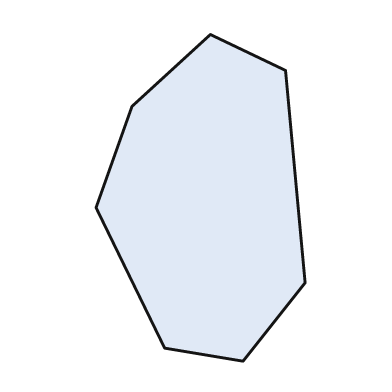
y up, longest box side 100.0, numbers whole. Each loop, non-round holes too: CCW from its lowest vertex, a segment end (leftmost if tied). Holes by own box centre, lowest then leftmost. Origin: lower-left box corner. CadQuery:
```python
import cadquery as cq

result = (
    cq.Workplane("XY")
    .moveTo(45.0, 0.0)
    .lineTo(64.0, 24.0)
    .lineTo(58.0, 89.0)
    .lineTo(35.0, 100.0)
    .lineTo(11.0, 78.0)
    .lineTo(0.0, 47.0)
    .lineTo(21.0, 4.0)
    .close()
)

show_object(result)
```